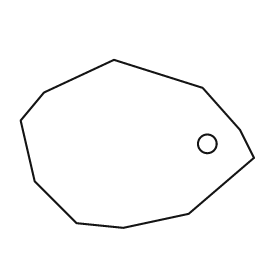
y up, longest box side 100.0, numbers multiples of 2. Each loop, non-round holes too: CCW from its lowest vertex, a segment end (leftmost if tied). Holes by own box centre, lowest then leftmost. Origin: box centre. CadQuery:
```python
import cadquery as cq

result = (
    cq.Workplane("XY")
    .moveTo(-6.0, -36.0)
    .lineTo(22.0, -30.0)
    .lineTo(50.0, -6.0)
    .lineTo(44.0, 6.0)
    .lineTo(28.0, 24.0)
    .lineTo(-10.0, 36.0)
    .lineTo(-40.0, 22.0)
    .lineTo(-50.0, 10.0)
    .lineTo(-44.0, -16.0)
    .lineTo(-26.0, -34.0)
    .close()
    .moveTo(30.0, 0.0)
    .circle(4.0)
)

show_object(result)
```